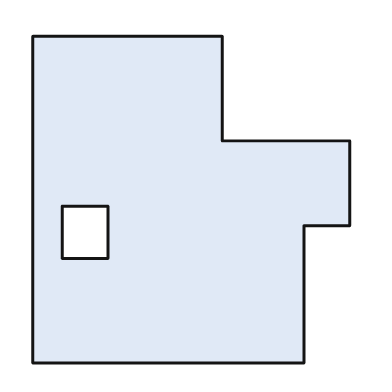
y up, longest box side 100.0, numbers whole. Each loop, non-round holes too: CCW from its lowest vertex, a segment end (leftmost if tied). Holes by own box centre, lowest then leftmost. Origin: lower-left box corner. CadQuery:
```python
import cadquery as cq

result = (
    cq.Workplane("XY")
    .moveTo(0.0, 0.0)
    .lineTo(83.0, 0.0)
    .lineTo(83.0, 42.0)
    .lineTo(97.0, 42.0)
    .lineTo(97.0, 68.0)
    .lineTo(58.0, 68.0)
    .lineTo(58.0, 100.0)
    .lineTo(0.0, 100.0)
    .close()
    .moveTo(9.0, 32.0)
    .lineTo(23.0, 32.0)
    .lineTo(23.0, 48.0)
    .lineTo(9.0, 48.0)
    .close()
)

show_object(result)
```